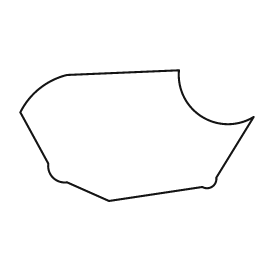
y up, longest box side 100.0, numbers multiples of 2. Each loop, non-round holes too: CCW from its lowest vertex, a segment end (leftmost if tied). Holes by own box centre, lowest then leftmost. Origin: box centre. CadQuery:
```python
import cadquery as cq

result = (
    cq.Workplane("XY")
    .moveTo(-12.0, -28.0)
    .lineTo(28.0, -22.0)
    .threePointArc((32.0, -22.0), (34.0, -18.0))
    .lineTo(50.0, 8.0)
    .threePointArc((28.0, 8.0), (18.0, 28.0))
    .lineTo(-30.0, 26.0)
    .threePointArc((-42.0, 20.0), (-50.0, 10.0))
    .lineTo(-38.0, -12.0)
    .threePointArc((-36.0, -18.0), (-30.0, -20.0))
    .close()
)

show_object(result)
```